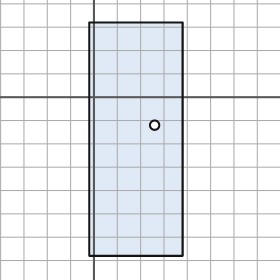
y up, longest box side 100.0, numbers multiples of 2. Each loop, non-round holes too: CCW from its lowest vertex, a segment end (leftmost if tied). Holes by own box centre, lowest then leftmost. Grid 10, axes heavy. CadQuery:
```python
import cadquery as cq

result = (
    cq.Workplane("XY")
    .moveTo(-2.0, -68.0)
    .lineTo(38.0, -68.0)
    .lineTo(38.0, 32.0)
    .lineTo(-2.0, 32.0)
    .close()
    .moveTo(26.0, -12.0)
    .circle(2.0)
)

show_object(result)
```